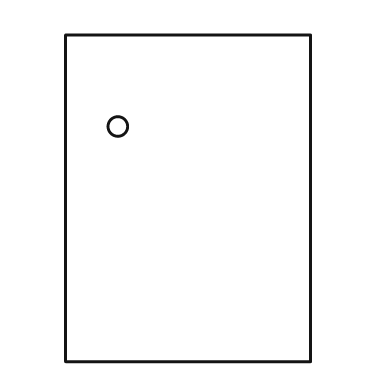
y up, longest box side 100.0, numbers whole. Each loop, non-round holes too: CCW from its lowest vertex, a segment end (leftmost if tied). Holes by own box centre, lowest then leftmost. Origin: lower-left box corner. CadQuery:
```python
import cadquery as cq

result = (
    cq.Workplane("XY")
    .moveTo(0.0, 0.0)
    .lineTo(75.0, 0.0)
    .lineTo(75.0, 100.0)
    .lineTo(0.0, 100.0)
    .close()
    .moveTo(16.0, 72.0)
    .circle(3.0)
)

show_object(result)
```